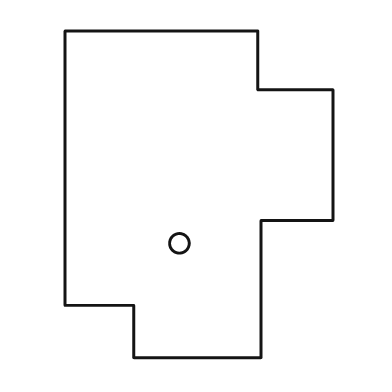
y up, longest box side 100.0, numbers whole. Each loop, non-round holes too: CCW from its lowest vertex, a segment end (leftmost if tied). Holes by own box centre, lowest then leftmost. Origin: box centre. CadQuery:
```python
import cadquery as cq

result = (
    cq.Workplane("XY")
    .moveTo(-20.0, -50.0)
    .lineTo(19.0, -50.0)
    .lineTo(19.0, -8.0)
    .lineTo(41.0, -8.0)
    .lineTo(41.0, 32.0)
    .lineTo(18.0, 32.0)
    .lineTo(18.0, 50.0)
    .lineTo(-41.0, 50.0)
    .lineTo(-41.0, -34.0)
    .lineTo(-20.0, -34.0)
    .close()
    .moveTo(-6.0, -15.0)
    .circle(3.0)
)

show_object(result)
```